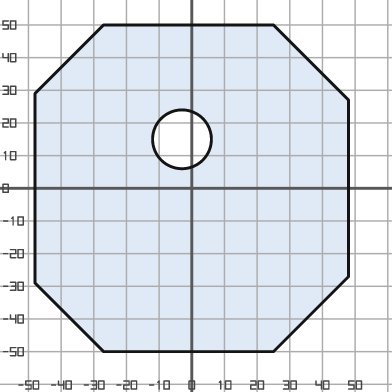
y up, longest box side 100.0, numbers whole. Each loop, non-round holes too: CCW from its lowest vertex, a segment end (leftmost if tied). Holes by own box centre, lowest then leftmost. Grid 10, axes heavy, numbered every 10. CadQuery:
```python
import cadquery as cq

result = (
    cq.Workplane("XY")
    .moveTo(-27.0, -50.0)
    .lineTo(25.0, -50.0)
    .lineTo(48.0, -27.0)
    .lineTo(48.0, 27.0)
    .lineTo(25.0, 50.0)
    .lineTo(-27.0, 50.0)
    .lineTo(-48.0, 29.0)
    .lineTo(-48.0, -29.0)
    .close()
    .moveTo(-3.0, 15.0)
    .circle(9.0)
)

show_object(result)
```